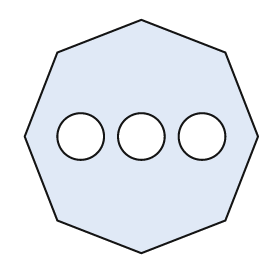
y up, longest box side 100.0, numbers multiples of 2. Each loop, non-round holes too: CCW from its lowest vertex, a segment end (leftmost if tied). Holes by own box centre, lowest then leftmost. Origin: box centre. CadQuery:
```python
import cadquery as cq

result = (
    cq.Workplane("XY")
    .moveTo(0.0, -50.0)
    .lineTo(36.0, -36.0)
    .lineTo(50.0, 0.0)
    .lineTo(36.0, 36.0)
    .lineTo(0.0, 50.0)
    .lineTo(-36.0, 36.0)
    .lineTo(-50.0, 0.0)
    .lineTo(-36.0, -36.0)
    .close()
    .moveTo(-26.0, 0.0)
    .circle(10.0)
    .moveTo(0.0, 0.0)
    .circle(10.0)
    .moveTo(26.0, 0.0)
    .circle(10.0)
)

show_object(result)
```